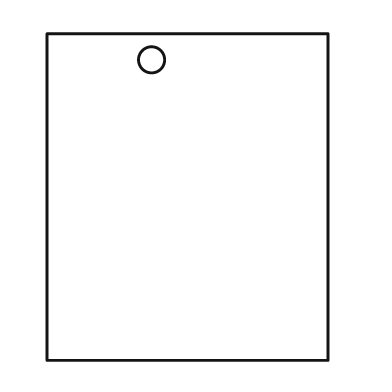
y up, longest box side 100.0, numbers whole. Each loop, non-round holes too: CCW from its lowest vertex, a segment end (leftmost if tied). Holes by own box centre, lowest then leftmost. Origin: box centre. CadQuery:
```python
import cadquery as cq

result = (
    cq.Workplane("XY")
    .moveTo(-43.0, -50.0)
    .lineTo(43.0, -50.0)
    .lineTo(43.0, 50.0)
    .lineTo(-43.0, 50.0)
    .close()
    .moveTo(-11.0, 42.0)
    .circle(4.0)
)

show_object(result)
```